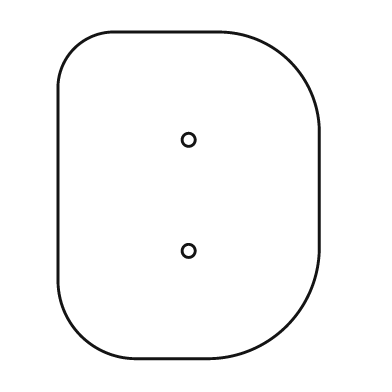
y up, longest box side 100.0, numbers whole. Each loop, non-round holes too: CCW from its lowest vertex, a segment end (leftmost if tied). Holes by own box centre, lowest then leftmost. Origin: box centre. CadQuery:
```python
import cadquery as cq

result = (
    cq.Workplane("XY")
    .moveTo(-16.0, -50.0)
    .lineTo(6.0, -50.0)
    .threePointArc((30.0, -40.0), (40.0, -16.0))
    .lineTo(40.0, 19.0)
    .threePointArc((31.0, 41.0), (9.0, 50.0))
    .lineTo(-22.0, 50.0)
    .threePointArc((-35.0, 45.0), (-40.0, 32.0))
    .lineTo(-40.0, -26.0)
    .threePointArc((-33.0, -43.0), (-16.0, -50.0))
    .close()
    .moveTo(0.0, -17.0)
    .circle(2.0)
    .moveTo(0.0, 17.0)
    .circle(2.0)
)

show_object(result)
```